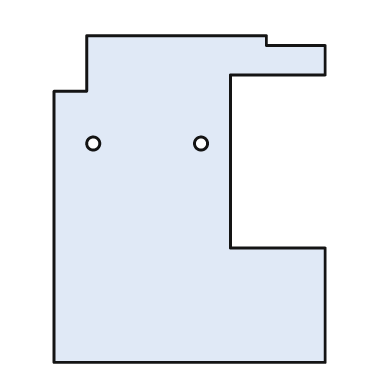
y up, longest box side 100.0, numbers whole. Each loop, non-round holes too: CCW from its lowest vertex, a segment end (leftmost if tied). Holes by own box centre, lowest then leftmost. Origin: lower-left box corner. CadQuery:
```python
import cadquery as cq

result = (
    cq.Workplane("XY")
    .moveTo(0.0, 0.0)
    .lineTo(83.0, 0.0)
    .lineTo(83.0, 35.0)
    .lineTo(54.0, 35.0)
    .lineTo(54.0, 88.0)
    .lineTo(83.0, 88.0)
    .lineTo(83.0, 97.0)
    .lineTo(65.0, 97.0)
    .lineTo(65.0, 100.0)
    .lineTo(10.0, 100.0)
    .lineTo(10.0, 83.0)
    .lineTo(0.0, 83.0)
    .close()
    .moveTo(12.0, 67.0)
    .circle(2.0)
    .moveTo(45.0, 67.0)
    .circle(2.0)
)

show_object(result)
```